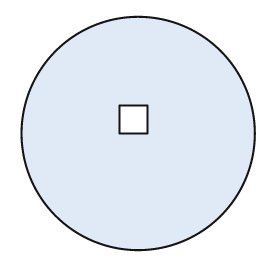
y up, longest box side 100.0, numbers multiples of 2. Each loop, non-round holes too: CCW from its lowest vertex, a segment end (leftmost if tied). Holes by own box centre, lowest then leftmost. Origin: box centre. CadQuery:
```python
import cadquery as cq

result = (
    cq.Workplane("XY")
    .moveTo(0.0, 0.0)
    .circle(50.0)
    .moveTo(-8.0, 0.0)
    .lineTo(4.0, 0.0)
    .lineTo(4.0, 12.0)
    .lineTo(-8.0, 12.0)
    .close()
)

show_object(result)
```